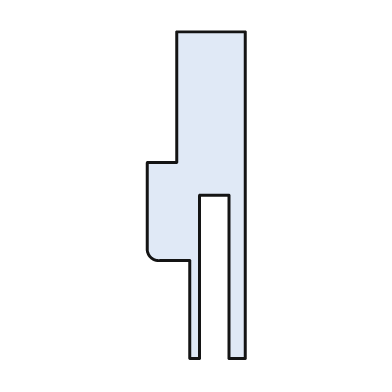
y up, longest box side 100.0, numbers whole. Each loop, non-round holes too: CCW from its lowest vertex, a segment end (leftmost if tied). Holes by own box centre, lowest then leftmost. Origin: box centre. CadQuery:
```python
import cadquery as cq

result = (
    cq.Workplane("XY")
    .moveTo(-2.0, -50.0)
    .lineTo(1.0, -50.0)
    .lineTo(1.0, 0.0)
    .lineTo(10.0, 0.0)
    .lineTo(10.0, -50.0)
    .lineTo(15.0, -50.0)
    .lineTo(15.0, 50.0)
    .lineTo(-6.0, 50.0)
    .lineTo(-6.0, 10.0)
    .lineTo(-15.0, 10.0)
    .lineTo(-15.0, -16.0)
    .threePointArc((-14.0, -19.0), (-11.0, -20.0))
    .lineTo(-2.0, -20.0)
    .close()
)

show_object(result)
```